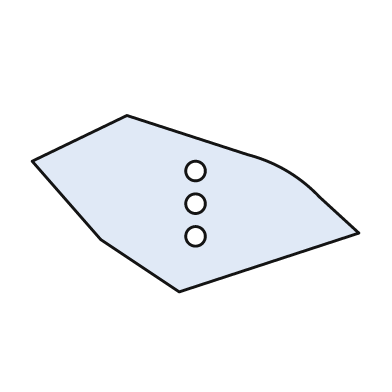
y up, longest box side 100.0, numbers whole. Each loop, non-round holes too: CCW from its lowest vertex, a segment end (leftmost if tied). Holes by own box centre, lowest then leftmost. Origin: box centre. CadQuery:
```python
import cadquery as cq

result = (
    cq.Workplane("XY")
    .moveTo(-5.0, -27.0)
    .lineTo(50.0, -9.0)
    .lineTo(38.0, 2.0)
    .threePointArc((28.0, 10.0), (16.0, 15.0))
    .lineTo(-21.0, 27.0)
    .lineTo(-50.0, 13.0)
    .lineTo(-29.0, -11.0)
    .close()
    .moveTo(0.0, -10.0)
    .circle(3.0)
    .moveTo(0.0, 0.0)
    .circle(3.0)
    .moveTo(0.0, 10.0)
    .circle(3.0)
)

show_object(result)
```